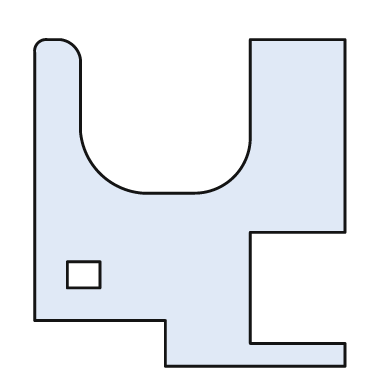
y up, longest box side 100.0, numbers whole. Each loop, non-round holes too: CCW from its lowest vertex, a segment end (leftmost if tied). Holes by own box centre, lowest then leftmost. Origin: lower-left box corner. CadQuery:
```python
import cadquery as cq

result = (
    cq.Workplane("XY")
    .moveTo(40.0, 0.0)
    .lineTo(95.0, 0.0)
    .lineTo(95.0, 7.0)
    .lineTo(66.0, 7.0)
    .lineTo(66.0, 41.0)
    .lineTo(95.0, 41.0)
    .lineTo(95.0, 100.0)
    .lineTo(66.0, 100.0)
    .lineTo(66.0, 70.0)
    .threePointArc((61.0, 58.0), (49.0, 53.0))
    .lineTo(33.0, 53.0)
    .threePointArc((20.0, 59.0), (14.0, 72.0))
    .lineTo(14.0, 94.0)
    .threePointArc((12.0, 98.0), (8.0, 100.0))
    .lineTo(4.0, 100.0)
    .threePointArc((1.0, 99.0), (0.0, 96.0))
    .lineTo(0.0, 14.0)
    .lineTo(40.0, 14.0)
    .close()
    .moveTo(10.0, 24.0)
    .lineTo(20.0, 24.0)
    .lineTo(20.0, 32.0)
    .lineTo(10.0, 32.0)
    .close()
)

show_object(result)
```